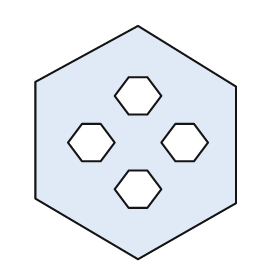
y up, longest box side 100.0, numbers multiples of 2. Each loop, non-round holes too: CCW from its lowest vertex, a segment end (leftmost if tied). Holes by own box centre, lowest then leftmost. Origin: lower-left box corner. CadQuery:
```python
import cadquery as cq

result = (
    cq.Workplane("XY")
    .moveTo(44.0, 0.0)
    .lineTo(86.0, 24.0)
    .lineTo(86.0, 74.0)
    .lineTo(44.0, 100.0)
    .lineTo(0.0, 76.0)
    .lineTo(0.0, 26.0)
    .close()
    .moveTo(40.0, 22.0)
    .lineTo(48.0, 22.0)
    .lineTo(54.0, 30.0)
    .lineTo(48.0, 38.0)
    .lineTo(40.0, 38.0)
    .lineTo(34.0, 30.0)
    .close()
    .moveTo(20.0, 42.0)
    .lineTo(28.0, 42.0)
    .lineTo(34.0, 50.0)
    .lineTo(28.0, 58.0)
    .lineTo(20.0, 58.0)
    .lineTo(14.0, 50.0)
    .close()
    .moveTo(60.0, 42.0)
    .lineTo(68.0, 42.0)
    .lineTo(74.0, 50.0)
    .lineTo(68.0, 58.0)
    .lineTo(60.0, 58.0)
    .lineTo(54.0, 50.0)
    .close()
    .moveTo(40.0, 62.0)
    .lineTo(48.0, 62.0)
    .lineTo(54.0, 70.0)
    .lineTo(48.0, 78.0)
    .lineTo(40.0, 78.0)
    .lineTo(34.0, 70.0)
    .close()
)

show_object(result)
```